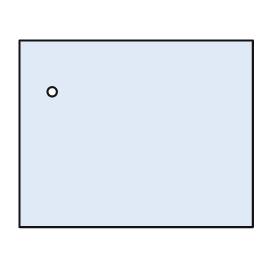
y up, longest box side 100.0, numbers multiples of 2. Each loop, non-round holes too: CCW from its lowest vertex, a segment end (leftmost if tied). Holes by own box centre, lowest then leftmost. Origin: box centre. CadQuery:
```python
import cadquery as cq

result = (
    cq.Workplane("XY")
    .moveTo(-50.0, -40.0)
    .lineTo(50.0, -40.0)
    .lineTo(50.0, 40.0)
    .lineTo(-50.0, 40.0)
    .close()
    .moveTo(-36.0, 18.0)
    .circle(2.0)
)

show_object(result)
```